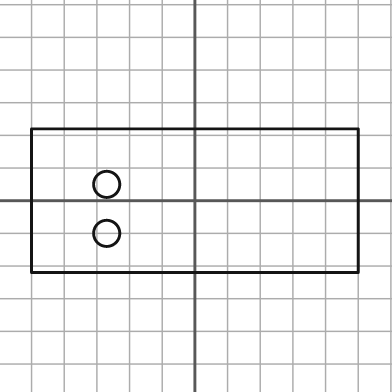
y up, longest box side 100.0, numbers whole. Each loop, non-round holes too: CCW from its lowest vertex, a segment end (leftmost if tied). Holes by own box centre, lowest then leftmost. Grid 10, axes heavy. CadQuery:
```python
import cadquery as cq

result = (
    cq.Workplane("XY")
    .moveTo(-50.0, -22.0)
    .lineTo(50.0, -22.0)
    .lineTo(50.0, 22.0)
    .lineTo(-50.0, 22.0)
    .close()
    .moveTo(-27.0, -10.0)
    .circle(4.0)
    .moveTo(-27.0, 5.0)
    .circle(4.0)
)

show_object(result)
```